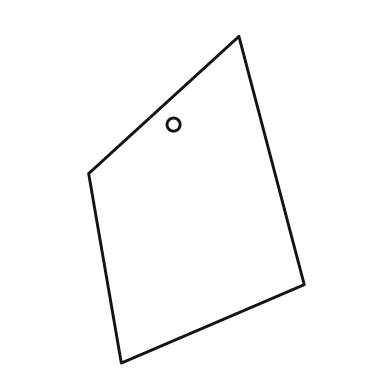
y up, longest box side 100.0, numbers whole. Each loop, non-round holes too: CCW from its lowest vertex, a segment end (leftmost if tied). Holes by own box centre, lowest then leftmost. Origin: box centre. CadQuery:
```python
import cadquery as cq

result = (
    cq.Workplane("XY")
    .moveTo(-23.0, -50.0)
    .lineTo(33.0, -26.0)
    .lineTo(13.0, 50.0)
    .lineTo(-33.0, 8.0)
    .close()
    .moveTo(-7.0, 23.0)
    .circle(2.0)
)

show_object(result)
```